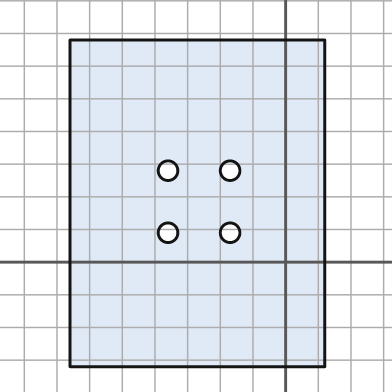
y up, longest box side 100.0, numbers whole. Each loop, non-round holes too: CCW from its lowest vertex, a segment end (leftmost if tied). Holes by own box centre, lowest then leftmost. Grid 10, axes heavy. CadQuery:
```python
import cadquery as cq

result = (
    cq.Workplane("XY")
    .moveTo(-66.0, -32.0)
    .lineTo(12.0, -32.0)
    .lineTo(12.0, 68.0)
    .lineTo(-66.0, 68.0)
    .close()
    .moveTo(-36.0, 9.0)
    .circle(3.0)
    .moveTo(-17.0, 9.0)
    .circle(3.0)
    .moveTo(-36.0, 28.0)
    .circle(3.0)
    .moveTo(-17.0, 28.0)
    .circle(3.0)
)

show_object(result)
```